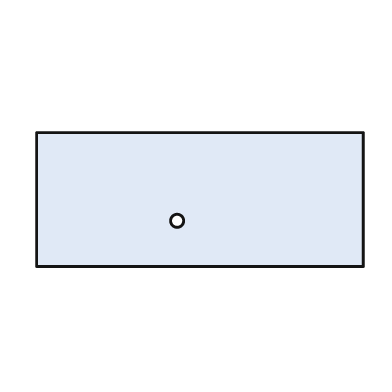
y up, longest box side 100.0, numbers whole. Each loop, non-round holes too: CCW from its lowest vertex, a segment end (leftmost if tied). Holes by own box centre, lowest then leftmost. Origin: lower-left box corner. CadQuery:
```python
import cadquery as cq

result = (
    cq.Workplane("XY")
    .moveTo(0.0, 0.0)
    .lineTo(100.0, 0.0)
    .lineTo(100.0, 41.0)
    .lineTo(0.0, 41.0)
    .close()
    .moveTo(43.0, 14.0)
    .circle(2.0)
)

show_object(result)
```